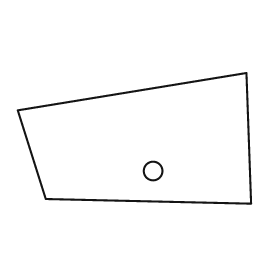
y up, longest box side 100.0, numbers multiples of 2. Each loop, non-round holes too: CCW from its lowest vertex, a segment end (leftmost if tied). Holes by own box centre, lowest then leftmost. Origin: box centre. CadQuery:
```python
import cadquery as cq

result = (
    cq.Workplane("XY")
    .moveTo(50.0, -28.0)
    .lineTo(48.0, 28.0)
    .lineTo(-50.0, 12.0)
    .lineTo(-38.0, -26.0)
    .close()
    .moveTo(8.0, -14.0)
    .circle(4.0)
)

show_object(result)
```